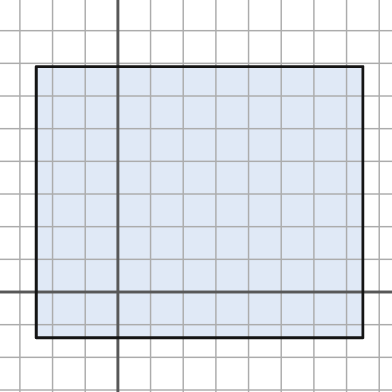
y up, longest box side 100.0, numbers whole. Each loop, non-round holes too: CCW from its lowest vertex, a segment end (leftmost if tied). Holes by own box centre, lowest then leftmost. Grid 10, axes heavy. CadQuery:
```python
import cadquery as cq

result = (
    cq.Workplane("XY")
    .moveTo(-25.0, -14.0)
    .lineTo(75.0, -14.0)
    .lineTo(75.0, 69.0)
    .lineTo(-25.0, 69.0)
    .close()
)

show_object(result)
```